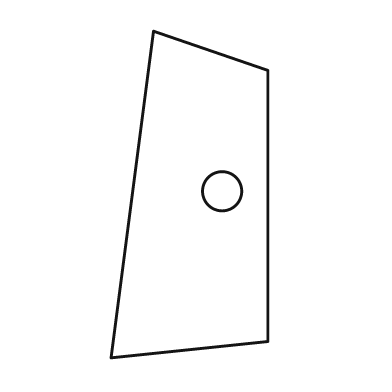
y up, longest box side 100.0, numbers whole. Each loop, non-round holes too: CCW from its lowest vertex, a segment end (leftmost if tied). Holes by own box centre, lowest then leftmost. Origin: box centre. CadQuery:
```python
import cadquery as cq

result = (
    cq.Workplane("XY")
    .moveTo(-24.0, -50.0)
    .lineTo(24.0, -45.0)
    .lineTo(24.0, 38.0)
    .lineTo(-11.0, 50.0)
    .close()
    .moveTo(10.0, 1.0)
    .circle(6.0)
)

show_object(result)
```